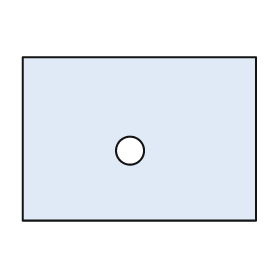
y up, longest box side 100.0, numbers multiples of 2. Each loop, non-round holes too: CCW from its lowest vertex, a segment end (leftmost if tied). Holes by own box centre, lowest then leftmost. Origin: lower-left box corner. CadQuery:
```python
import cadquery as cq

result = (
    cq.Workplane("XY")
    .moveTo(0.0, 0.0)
    .lineTo(100.0, 0.0)
    .lineTo(100.0, 70.0)
    .lineTo(0.0, 70.0)
    .close()
    .moveTo(46.0, 30.0)
    .circle(6.0)
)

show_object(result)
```